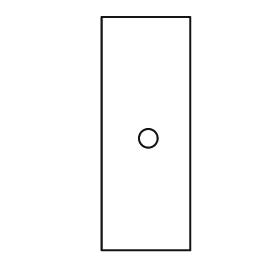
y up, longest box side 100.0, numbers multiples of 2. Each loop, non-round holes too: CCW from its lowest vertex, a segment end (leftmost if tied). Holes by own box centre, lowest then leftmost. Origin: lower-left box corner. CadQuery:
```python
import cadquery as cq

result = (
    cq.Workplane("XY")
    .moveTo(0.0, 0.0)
    .lineTo(38.0, 0.0)
    .lineTo(38.0, 100.0)
    .lineTo(0.0, 100.0)
    .close()
    .moveTo(20.0, 48.0)
    .circle(4.0)
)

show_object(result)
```